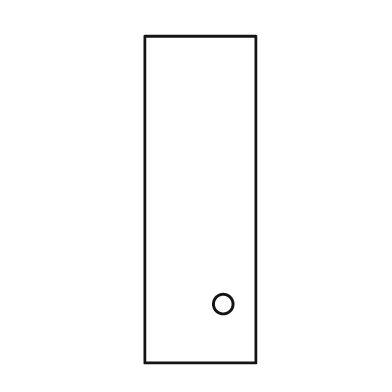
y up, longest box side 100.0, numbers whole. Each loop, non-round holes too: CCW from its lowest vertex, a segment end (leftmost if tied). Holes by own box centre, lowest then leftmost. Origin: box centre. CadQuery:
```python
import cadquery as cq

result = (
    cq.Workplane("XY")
    .moveTo(-17.0, -50.0)
    .lineTo(17.0, -50.0)
    .lineTo(17.0, 50.0)
    .lineTo(-17.0, 50.0)
    .close()
    .moveTo(7.0, -32.0)
    .circle(3.0)
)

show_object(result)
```